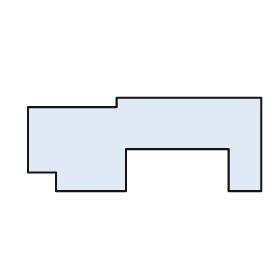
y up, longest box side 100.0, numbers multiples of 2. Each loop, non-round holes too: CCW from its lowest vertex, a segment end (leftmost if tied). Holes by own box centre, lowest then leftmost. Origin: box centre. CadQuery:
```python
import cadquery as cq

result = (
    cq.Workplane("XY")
    .moveTo(-38.0, -20.0)
    .lineTo(-8.0, -20.0)
    .lineTo(-8.0, -2.0)
    .lineTo(36.0, -2.0)
    .lineTo(36.0, -20.0)
    .lineTo(50.0, -20.0)
    .lineTo(50.0, 20.0)
    .lineTo(-12.0, 20.0)
    .lineTo(-12.0, 16.0)
    .lineTo(-50.0, 16.0)
    .lineTo(-50.0, -12.0)
    .lineTo(-38.0, -12.0)
    .close()
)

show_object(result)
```